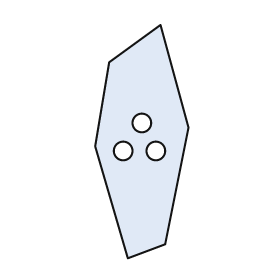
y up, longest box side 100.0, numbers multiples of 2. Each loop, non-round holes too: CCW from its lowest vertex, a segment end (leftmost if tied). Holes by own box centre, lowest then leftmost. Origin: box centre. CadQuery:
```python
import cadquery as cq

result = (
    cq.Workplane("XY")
    .moveTo(-6.0, -50.0)
    .lineTo(10.0, -44.0)
    .lineTo(20.0, 6.0)
    .lineTo(8.0, 50.0)
    .lineTo(-14.0, 34.0)
    .lineTo(-20.0, -2.0)
    .close()
    .moveTo(-8.0, -4.0)
    .circle(4.0)
    .moveTo(6.0, -4.0)
    .circle(4.0)
    .moveTo(0.0, 8.0)
    .circle(4.0)
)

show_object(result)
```